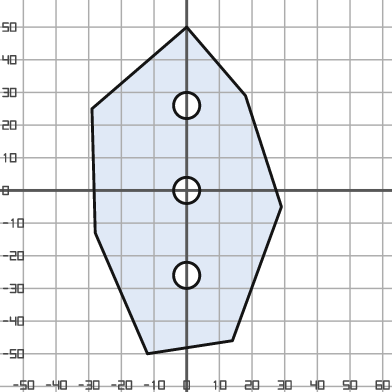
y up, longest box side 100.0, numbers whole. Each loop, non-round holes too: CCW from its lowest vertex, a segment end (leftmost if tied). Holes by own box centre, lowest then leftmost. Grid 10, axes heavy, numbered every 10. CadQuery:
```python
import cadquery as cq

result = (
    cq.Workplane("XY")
    .moveTo(-12.0, -50.0)
    .lineTo(14.0, -46.0)
    .lineTo(29.0, -5.0)
    .lineTo(18.0, 29.0)
    .lineTo(0.0, 50.0)
    .lineTo(-29.0, 25.0)
    .lineTo(-28.0, -13.0)
    .close()
    .moveTo(0.0, -26.0)
    .circle(4.0)
    .moveTo(0.0, 0.0)
    .circle(4.0)
    .moveTo(0.0, 26.0)
    .circle(4.0)
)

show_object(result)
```